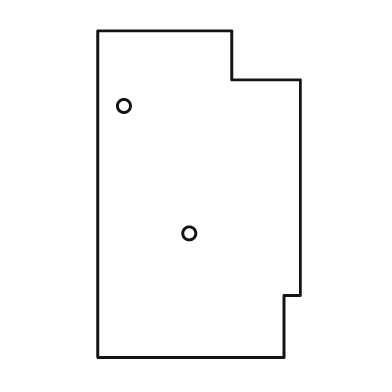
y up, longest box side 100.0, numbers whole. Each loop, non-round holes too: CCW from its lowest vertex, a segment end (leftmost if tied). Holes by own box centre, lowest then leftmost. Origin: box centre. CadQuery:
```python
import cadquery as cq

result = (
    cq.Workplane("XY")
    .moveTo(-31.0, -50.0)
    .lineTo(26.0, -50.0)
    .lineTo(26.0, -31.0)
    .lineTo(31.0, -31.0)
    .lineTo(31.0, 35.0)
    .lineTo(10.0, 35.0)
    .lineTo(10.0, 50.0)
    .lineTo(-31.0, 50.0)
    .close()
    .moveTo(-3.0, -12.0)
    .circle(2.0)
    .moveTo(-23.0, 27.0)
    .circle(2.0)
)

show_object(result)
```